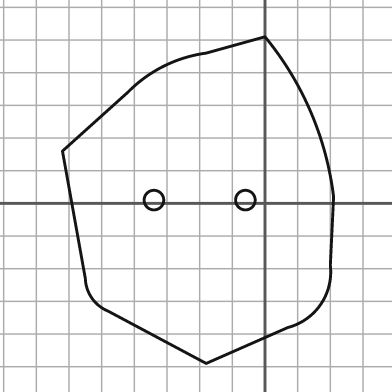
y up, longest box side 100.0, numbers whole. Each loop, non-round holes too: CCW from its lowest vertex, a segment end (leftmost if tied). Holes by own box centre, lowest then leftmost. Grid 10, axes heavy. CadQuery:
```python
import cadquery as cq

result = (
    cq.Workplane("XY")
    .moveTo(-18.0, -49.0)
    .lineTo(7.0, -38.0)
    .threePointArc((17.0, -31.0), (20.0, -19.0))
    .lineTo(21.0, 2.0)
    .threePointArc((14.0, 28.0), (0.0, 51.0))
    .lineTo(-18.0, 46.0)
    .threePointArc((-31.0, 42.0), (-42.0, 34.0))
    .lineTo(-62.0, 16.0)
    .lineTo(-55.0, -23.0)
    .threePointArc((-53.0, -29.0), (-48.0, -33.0))
    .close()
    .moveTo(-34.0, 1.0)
    .circle(3.0)
    .moveTo(-6.0, 1.0)
    .circle(3.0)
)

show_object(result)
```